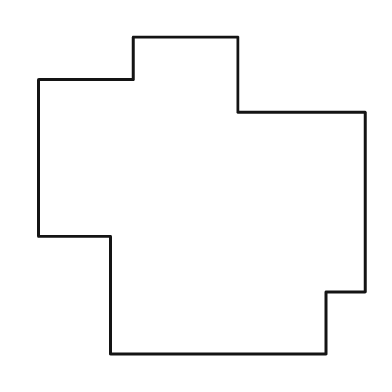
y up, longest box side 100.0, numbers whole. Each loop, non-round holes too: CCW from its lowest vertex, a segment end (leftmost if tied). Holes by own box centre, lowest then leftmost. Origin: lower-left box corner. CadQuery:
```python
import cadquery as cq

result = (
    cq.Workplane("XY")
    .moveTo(22.0, 0.0)
    .lineTo(88.0, 0.0)
    .lineTo(88.0, 19.0)
    .lineTo(100.0, 19.0)
    .lineTo(100.0, 74.0)
    .lineTo(61.0, 74.0)
    .lineTo(61.0, 97.0)
    .lineTo(29.0, 97.0)
    .lineTo(29.0, 84.0)
    .lineTo(0.0, 84.0)
    .lineTo(0.0, 36.0)
    .lineTo(22.0, 36.0)
    .close()
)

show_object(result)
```